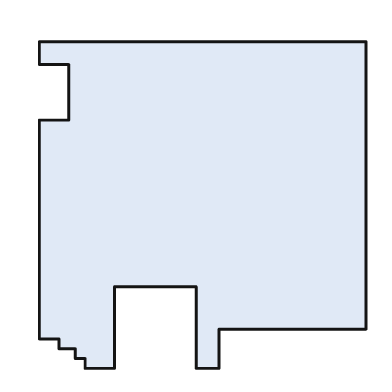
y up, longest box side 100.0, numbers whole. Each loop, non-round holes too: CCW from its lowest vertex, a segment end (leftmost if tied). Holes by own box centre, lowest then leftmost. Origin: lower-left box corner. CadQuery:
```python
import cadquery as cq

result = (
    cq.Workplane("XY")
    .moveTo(14.0, 0.0)
    .lineTo(23.0, 0.0)
    .lineTo(23.0, 25.0)
    .lineTo(48.0, 25.0)
    .lineTo(48.0, 0.0)
    .lineTo(55.0, 0.0)
    .lineTo(55.0, 12.0)
    .lineTo(100.0, 12.0)
    .lineTo(100.0, 100.0)
    .lineTo(0.0, 100.0)
    .lineTo(0.0, 93.0)
    .lineTo(9.0, 93.0)
    .lineTo(9.0, 76.0)
    .lineTo(0.0, 76.0)
    .lineTo(0.0, 9.0)
    .lineTo(6.0, 9.0)
    .lineTo(6.0, 6.0)
    .lineTo(11.0, 6.0)
    .lineTo(11.0, 3.0)
    .lineTo(14.0, 3.0)
    .close()
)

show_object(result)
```